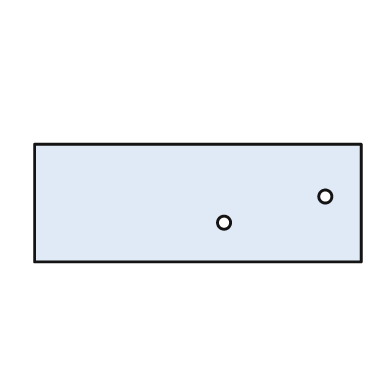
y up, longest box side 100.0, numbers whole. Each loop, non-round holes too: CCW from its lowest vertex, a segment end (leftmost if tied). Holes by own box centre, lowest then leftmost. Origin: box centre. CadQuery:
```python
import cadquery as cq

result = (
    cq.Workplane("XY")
    .moveTo(-50.0, -18.0)
    .lineTo(50.0, -18.0)
    .lineTo(50.0, 18.0)
    .lineTo(-50.0, 18.0)
    .close()
    .moveTo(8.0, -6.0)
    .circle(2.0)
    .moveTo(39.0, 2.0)
    .circle(2.0)
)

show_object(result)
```